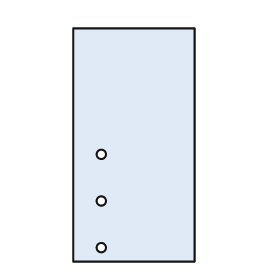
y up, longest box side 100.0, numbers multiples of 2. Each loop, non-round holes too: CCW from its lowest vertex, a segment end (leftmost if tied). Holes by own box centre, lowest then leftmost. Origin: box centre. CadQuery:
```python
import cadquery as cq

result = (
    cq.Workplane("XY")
    .moveTo(-26.0, -50.0)
    .lineTo(26.0, -50.0)
    .lineTo(26.0, 50.0)
    .lineTo(-26.0, 50.0)
    .close()
    .moveTo(-14.0, -44.0)
    .circle(2.0)
    .moveTo(-14.0, -24.0)
    .circle(2.0)
    .moveTo(-14.0, -4.0)
    .circle(2.0)
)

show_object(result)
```